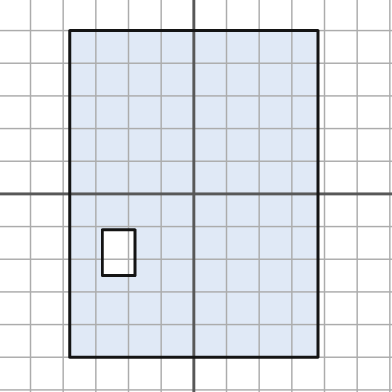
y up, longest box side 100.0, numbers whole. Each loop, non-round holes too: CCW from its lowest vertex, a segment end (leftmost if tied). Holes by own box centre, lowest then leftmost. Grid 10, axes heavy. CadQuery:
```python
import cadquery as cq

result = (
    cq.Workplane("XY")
    .moveTo(-38.0, -50.0)
    .lineTo(38.0, -50.0)
    .lineTo(38.0, 50.0)
    .lineTo(-38.0, 50.0)
    .close()
    .moveTo(-28.0, -25.0)
    .lineTo(-18.0, -25.0)
    .lineTo(-18.0, -11.0)
    .lineTo(-28.0, -11.0)
    .close()
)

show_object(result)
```